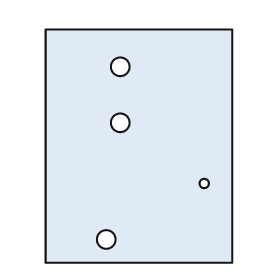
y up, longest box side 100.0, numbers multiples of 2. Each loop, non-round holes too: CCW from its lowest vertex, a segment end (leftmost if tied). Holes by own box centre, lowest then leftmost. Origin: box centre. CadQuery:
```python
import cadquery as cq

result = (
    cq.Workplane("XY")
    .moveTo(-40.0, -50.0)
    .lineTo(40.0, -50.0)
    .lineTo(40.0, 50.0)
    .lineTo(-40.0, 50.0)
    .close()
    .moveTo(-14.0, -40.0)
    .circle(4.0)
    .moveTo(28.0, -16.0)
    .circle(2.0)
    .moveTo(-8.0, 10.0)
    .circle(4.0)
    .moveTo(-8.0, 34.0)
    .circle(4.0)
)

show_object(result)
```